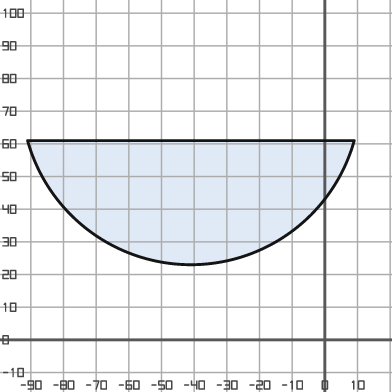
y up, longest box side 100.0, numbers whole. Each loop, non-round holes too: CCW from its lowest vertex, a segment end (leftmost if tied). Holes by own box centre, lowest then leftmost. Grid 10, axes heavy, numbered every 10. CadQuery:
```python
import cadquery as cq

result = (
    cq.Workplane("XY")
    .moveTo(-91.0, 61.0)
    .threePointArc((-41.0, 23.0), (9.0, 61.0))
    .close()
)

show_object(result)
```